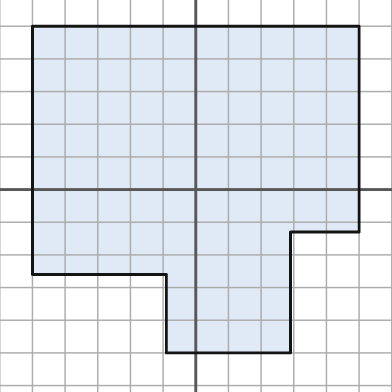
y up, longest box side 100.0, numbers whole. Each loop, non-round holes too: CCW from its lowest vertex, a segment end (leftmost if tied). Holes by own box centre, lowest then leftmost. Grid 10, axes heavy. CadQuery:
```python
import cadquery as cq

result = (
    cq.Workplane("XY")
    .moveTo(-9.0, -50.0)
    .lineTo(29.0, -50.0)
    .lineTo(29.0, -13.0)
    .lineTo(50.0, -13.0)
    .lineTo(50.0, 50.0)
    .lineTo(-50.0, 50.0)
    .lineTo(-50.0, -26.0)
    .lineTo(-9.0, -26.0)
    .close()
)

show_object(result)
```